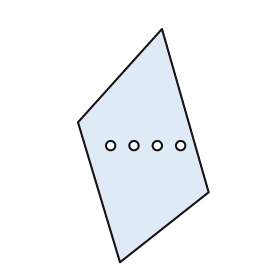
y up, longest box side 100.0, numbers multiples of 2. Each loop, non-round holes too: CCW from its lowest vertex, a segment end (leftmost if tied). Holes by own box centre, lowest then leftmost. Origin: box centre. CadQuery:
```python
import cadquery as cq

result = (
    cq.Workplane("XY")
    .moveTo(-10.0, -50.0)
    .lineTo(28.0, -20.0)
    .lineTo(8.0, 50.0)
    .lineTo(-28.0, 10.0)
    .close()
    .moveTo(-14.0, 0.0)
    .circle(2.0)
    .moveTo(-4.0, 0.0)
    .circle(2.0)
    .moveTo(6.0, 0.0)
    .circle(2.0)
    .moveTo(16.0, 0.0)
    .circle(2.0)
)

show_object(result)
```